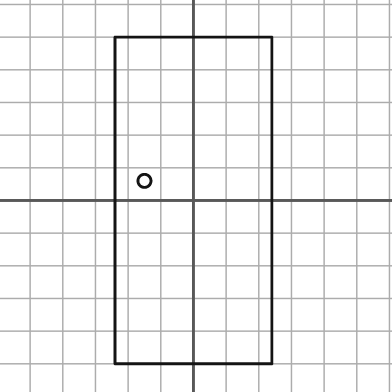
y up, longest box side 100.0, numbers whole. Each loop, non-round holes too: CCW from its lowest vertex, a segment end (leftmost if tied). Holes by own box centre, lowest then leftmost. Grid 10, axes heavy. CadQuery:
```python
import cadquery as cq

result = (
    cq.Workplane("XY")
    .moveTo(-24.0, -50.0)
    .lineTo(24.0, -50.0)
    .lineTo(24.0, 50.0)
    .lineTo(-24.0, 50.0)
    .close()
    .moveTo(-15.0, 6.0)
    .circle(2.0)
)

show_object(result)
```